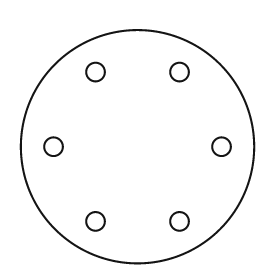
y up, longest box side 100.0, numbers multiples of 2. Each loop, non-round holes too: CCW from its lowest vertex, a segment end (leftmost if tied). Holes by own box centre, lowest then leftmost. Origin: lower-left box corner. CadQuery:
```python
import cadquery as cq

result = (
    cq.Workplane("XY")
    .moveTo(50.0, 50.0)
    .circle(50.0)
    .moveTo(32.0, 18.0)
    .circle(4.0)
    .moveTo(68.0, 18.0)
    .circle(4.0)
    .moveTo(14.0, 50.0)
    .circle(4.0)
    .moveTo(86.0, 50.0)
    .circle(4.0)
    .moveTo(32.0, 82.0)
    .circle(4.0)
    .moveTo(68.0, 82.0)
    .circle(4.0)
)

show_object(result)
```